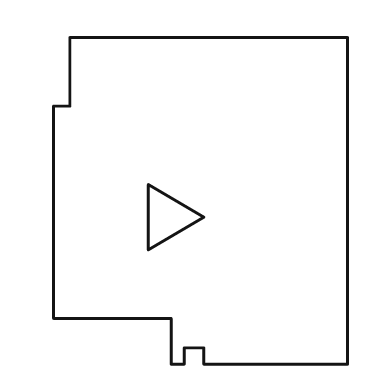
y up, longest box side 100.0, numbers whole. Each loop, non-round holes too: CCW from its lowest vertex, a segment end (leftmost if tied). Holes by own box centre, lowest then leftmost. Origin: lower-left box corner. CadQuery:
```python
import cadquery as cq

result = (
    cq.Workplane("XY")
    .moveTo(36.0, 0.0)
    .lineTo(40.0, 0.0)
    .lineTo(40.0, 5.0)
    .lineTo(46.0, 5.0)
    .lineTo(46.0, 0.0)
    .lineTo(90.0, 0.0)
    .lineTo(90.0, 100.0)
    .lineTo(5.0, 100.0)
    .lineTo(5.0, 79.0)
    .lineTo(0.0, 79.0)
    .lineTo(0.0, 14.0)
    .lineTo(36.0, 14.0)
    .close()
    .moveTo(29.0, 35.0)
    .lineTo(46.0, 45.0)
    .lineTo(29.0, 55.0)
    .close()
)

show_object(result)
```